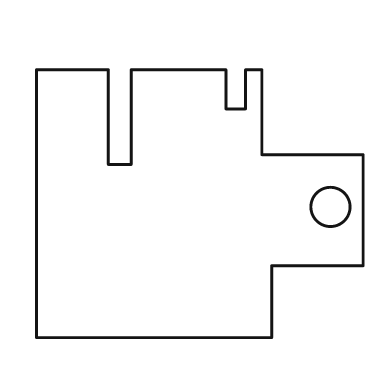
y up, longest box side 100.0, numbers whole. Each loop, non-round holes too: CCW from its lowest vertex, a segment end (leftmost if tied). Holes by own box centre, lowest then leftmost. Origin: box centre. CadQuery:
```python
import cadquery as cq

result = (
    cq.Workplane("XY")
    .moveTo(-50.0, -41.0)
    .lineTo(22.0, -41.0)
    .lineTo(22.0, -19.0)
    .lineTo(50.0, -19.0)
    .lineTo(50.0, 15.0)
    .lineTo(19.0, 15.0)
    .lineTo(19.0, 41.0)
    .lineTo(14.0, 41.0)
    .lineTo(14.0, 29.0)
    .lineTo(8.0, 29.0)
    .lineTo(8.0, 41.0)
    .lineTo(-21.0, 41.0)
    .lineTo(-21.0, 12.0)
    .lineTo(-28.0, 12.0)
    .lineTo(-28.0, 41.0)
    .lineTo(-50.0, 41.0)
    .close()
    .moveTo(40.0, -1.0)
    .circle(6.0)
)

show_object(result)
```